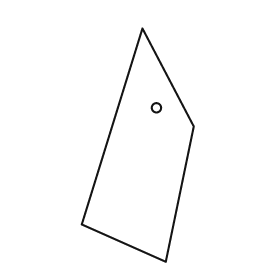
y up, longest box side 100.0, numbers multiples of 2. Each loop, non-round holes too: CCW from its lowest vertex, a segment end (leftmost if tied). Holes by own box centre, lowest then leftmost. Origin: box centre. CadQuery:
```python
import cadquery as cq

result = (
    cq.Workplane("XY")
    .moveTo(12.0, -50.0)
    .lineTo(24.0, 8.0)
    .lineTo(2.0, 50.0)
    .lineTo(-24.0, -34.0)
    .close()
    .moveTo(8.0, 16.0)
    .circle(2.0)
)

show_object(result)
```